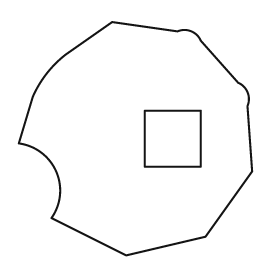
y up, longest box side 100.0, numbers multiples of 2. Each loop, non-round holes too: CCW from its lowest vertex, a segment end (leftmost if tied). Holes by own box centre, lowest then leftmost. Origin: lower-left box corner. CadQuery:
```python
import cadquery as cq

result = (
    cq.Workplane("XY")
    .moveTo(46.0, 0.0)
    .lineTo(80.0, 8.0)
    .lineTo(100.0, 36.0)
    .lineTo(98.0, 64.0)
    .threePointArc((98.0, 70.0), (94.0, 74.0))
    .lineTo(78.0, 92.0)
    .threePointArc((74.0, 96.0), (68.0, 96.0))
    .lineTo(40.0, 100.0)
    .lineTo(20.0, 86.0)
    .threePointArc((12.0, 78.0), (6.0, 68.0))
    .lineTo(0.0, 48.0)
    .threePointArc((16.0, 36.0), (14.0, 16.0))
    .close()
    .moveTo(54.0, 38.0)
    .lineTo(78.0, 38.0)
    .lineTo(78.0, 62.0)
    .lineTo(54.0, 62.0)
    .close()
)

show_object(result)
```